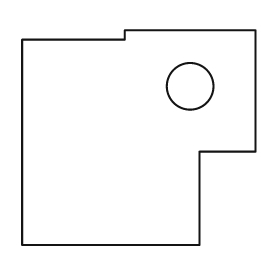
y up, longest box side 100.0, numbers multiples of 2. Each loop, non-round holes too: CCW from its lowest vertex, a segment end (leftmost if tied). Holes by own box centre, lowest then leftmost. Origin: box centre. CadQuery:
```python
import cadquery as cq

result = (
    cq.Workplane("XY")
    .moveTo(-50.0, -46.0)
    .lineTo(26.0, -46.0)
    .lineTo(26.0, -6.0)
    .lineTo(50.0, -6.0)
    .lineTo(50.0, 46.0)
    .lineTo(-6.0, 46.0)
    .lineTo(-6.0, 42.0)
    .lineTo(-50.0, 42.0)
    .close()
    .moveTo(22.0, 22.0)
    .circle(10.0)
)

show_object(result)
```